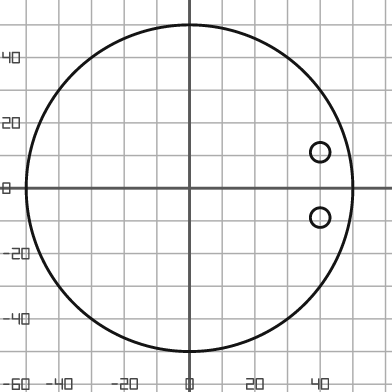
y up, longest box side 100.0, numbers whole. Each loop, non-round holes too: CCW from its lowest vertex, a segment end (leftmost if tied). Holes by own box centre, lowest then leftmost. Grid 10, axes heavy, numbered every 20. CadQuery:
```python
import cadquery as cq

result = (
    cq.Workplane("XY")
    .moveTo(0.0, 0.0)
    .circle(50.0)
    .moveTo(40.0, -9.0)
    .circle(3.0)
    .moveTo(40.0, 11.0)
    .circle(3.0)
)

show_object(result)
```